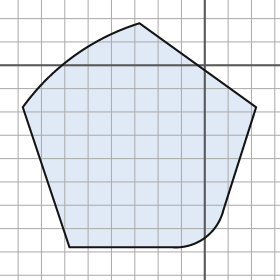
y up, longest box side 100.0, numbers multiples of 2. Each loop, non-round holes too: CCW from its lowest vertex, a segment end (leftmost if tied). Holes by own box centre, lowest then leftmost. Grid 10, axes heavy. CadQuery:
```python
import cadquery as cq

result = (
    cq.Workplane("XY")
    .moveTo(-58.0, -78.0)
    .lineTo(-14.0, -78.0)
    .threePointArc((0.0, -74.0), (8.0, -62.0))
    .lineTo(22.0, -18.0)
    .lineTo(-28.0, 18.0)
    .threePointArc((-56.0, 4.0), (-78.0, -18.0))
    .close()
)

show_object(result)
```